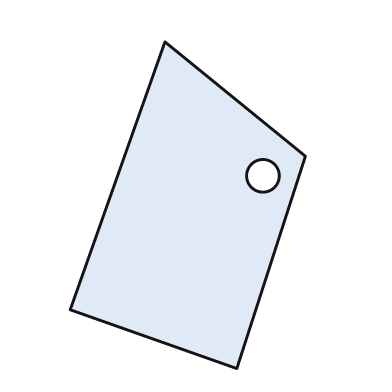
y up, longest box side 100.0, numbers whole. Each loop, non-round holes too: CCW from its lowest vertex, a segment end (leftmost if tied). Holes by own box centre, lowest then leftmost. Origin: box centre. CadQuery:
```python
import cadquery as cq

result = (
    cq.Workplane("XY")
    .moveTo(15.0, -50.0)
    .lineTo(36.0, 15.0)
    .lineTo(-7.0, 50.0)
    .lineTo(-36.0, -32.0)
    .close()
    .moveTo(23.0, 9.0)
    .circle(5.0)
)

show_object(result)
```